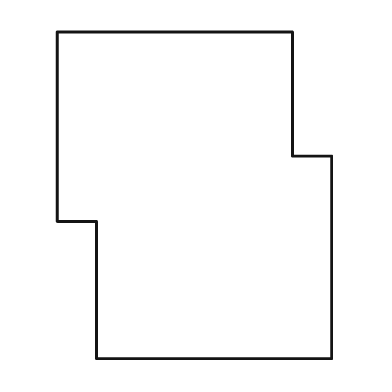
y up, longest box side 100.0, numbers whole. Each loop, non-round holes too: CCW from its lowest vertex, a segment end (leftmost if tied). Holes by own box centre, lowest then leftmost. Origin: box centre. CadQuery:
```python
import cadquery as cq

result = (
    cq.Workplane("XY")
    .moveTo(-30.0, -50.0)
    .lineTo(42.0, -50.0)
    .lineTo(42.0, 12.0)
    .lineTo(30.0, 12.0)
    .lineTo(30.0, 50.0)
    .lineTo(-42.0, 50.0)
    .lineTo(-42.0, -8.0)
    .lineTo(-30.0, -8.0)
    .close()
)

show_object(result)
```